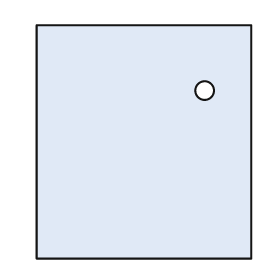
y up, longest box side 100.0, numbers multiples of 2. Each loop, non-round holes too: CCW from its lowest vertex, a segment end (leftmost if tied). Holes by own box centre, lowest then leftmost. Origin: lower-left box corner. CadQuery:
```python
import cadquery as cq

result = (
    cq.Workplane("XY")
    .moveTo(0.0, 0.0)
    .lineTo(92.0, 0.0)
    .lineTo(92.0, 100.0)
    .lineTo(0.0, 100.0)
    .close()
    .moveTo(72.0, 72.0)
    .circle(4.0)
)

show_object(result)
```